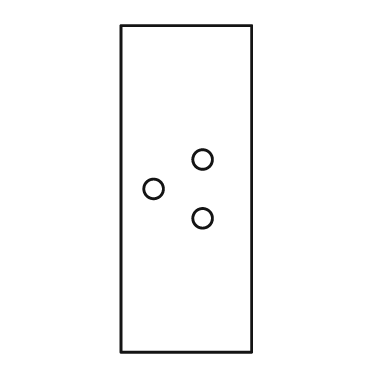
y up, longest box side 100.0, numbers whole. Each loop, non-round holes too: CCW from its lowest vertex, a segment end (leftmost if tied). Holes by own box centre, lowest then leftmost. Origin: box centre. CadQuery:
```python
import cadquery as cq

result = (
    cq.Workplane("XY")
    .moveTo(-20.0, -50.0)
    .lineTo(20.0, -50.0)
    .lineTo(20.0, 50.0)
    .lineTo(-20.0, 50.0)
    .close()
    .moveTo(5.0, -9.0)
    .circle(3.0)
    .moveTo(-10.0, 0.0)
    .circle(3.0)
    .moveTo(5.0, 9.0)
    .circle(3.0)
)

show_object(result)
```